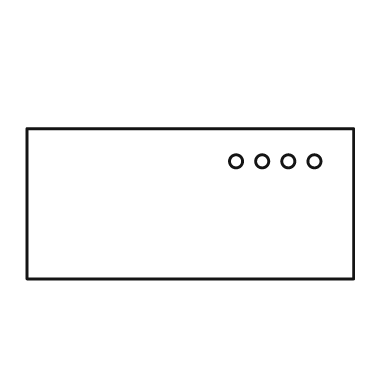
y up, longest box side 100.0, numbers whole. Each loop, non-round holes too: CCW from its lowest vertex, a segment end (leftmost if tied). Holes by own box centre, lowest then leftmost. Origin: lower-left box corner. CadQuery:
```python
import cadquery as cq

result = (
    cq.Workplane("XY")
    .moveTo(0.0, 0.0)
    .lineTo(100.0, 0.0)
    .lineTo(100.0, 46.0)
    .lineTo(0.0, 46.0)
    .close()
    .moveTo(64.0, 36.0)
    .circle(2.0)
    .moveTo(72.0, 36.0)
    .circle(2.0)
    .moveTo(80.0, 36.0)
    .circle(2.0)
    .moveTo(88.0, 36.0)
    .circle(2.0)
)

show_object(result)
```